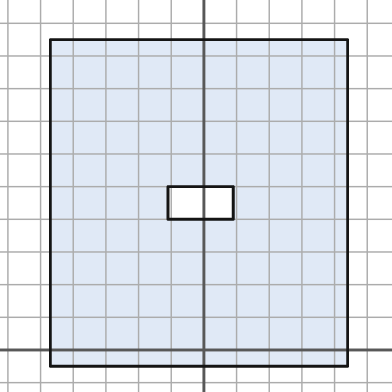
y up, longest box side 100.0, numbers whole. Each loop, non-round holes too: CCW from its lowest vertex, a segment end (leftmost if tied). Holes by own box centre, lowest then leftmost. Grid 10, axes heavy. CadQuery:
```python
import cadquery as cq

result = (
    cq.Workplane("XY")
    .moveTo(-47.0, -5.0)
    .lineTo(44.0, -5.0)
    .lineTo(44.0, 95.0)
    .lineTo(-47.0, 95.0)
    .close()
    .moveTo(-11.0, 40.0)
    .lineTo(9.0, 40.0)
    .lineTo(9.0, 50.0)
    .lineTo(-11.0, 50.0)
    .close()
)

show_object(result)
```